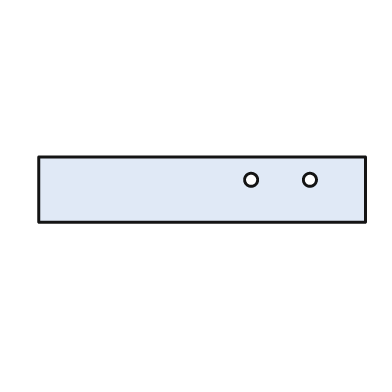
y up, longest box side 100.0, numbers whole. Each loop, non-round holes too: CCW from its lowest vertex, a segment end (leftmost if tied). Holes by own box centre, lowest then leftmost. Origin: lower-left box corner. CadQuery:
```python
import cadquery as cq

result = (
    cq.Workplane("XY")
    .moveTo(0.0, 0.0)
    .lineTo(100.0, 0.0)
    .lineTo(100.0, 20.0)
    .lineTo(0.0, 20.0)
    .close()
    .moveTo(65.0, 13.0)
    .circle(2.0)
    .moveTo(83.0, 13.0)
    .circle(2.0)
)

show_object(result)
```